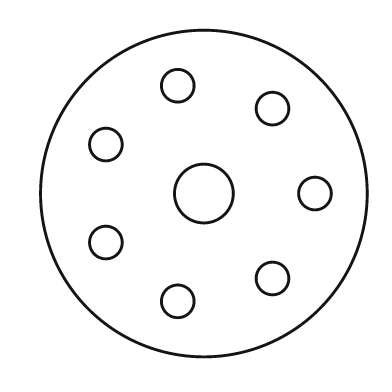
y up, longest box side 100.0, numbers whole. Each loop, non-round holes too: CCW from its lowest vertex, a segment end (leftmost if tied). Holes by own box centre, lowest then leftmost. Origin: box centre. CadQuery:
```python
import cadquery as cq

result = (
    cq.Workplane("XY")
    .moveTo(0.0, 0.0)
    .circle(50.0)
    .moveTo(-8.0, -33.0)
    .circle(5.0)
    .moveTo(21.0, -26.0)
    .circle(5.0)
    .moveTo(-30.0, -15.0)
    .circle(5.0)
    .moveTo(0.0, 0.0)
    .circle(9.0)
    .moveTo(34.0, 0.0)
    .circle(5.0)
    .moveTo(-30.0, 15.0)
    .circle(5.0)
    .moveTo(21.0, 26.0)
    .circle(5.0)
    .moveTo(-8.0, 33.0)
    .circle(5.0)
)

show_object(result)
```